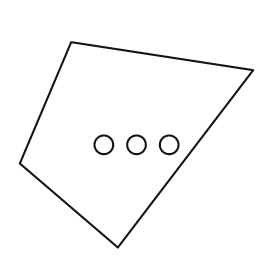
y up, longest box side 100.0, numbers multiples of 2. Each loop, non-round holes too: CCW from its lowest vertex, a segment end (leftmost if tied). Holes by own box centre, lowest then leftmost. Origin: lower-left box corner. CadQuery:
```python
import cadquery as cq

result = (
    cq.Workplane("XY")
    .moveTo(42.0, 0.0)
    .lineTo(100.0, 76.0)
    .lineTo(22.0, 88.0)
    .lineTo(0.0, 36.0)
    .close()
    .moveTo(36.0, 44.0)
    .circle(4.0)
    .moveTo(50.0, 44.0)
    .circle(4.0)
    .moveTo(64.0, 44.0)
    .circle(4.0)
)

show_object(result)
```